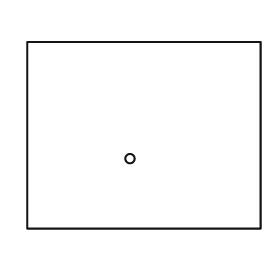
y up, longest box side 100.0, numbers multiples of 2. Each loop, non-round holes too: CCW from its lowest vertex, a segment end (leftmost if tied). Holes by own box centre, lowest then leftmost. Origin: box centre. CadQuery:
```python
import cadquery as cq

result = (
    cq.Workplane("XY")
    .moveTo(-50.0, -40.0)
    .lineTo(50.0, -40.0)
    .lineTo(50.0, 40.0)
    .lineTo(-50.0, 40.0)
    .close()
    .moveTo(-6.0, -10.0)
    .circle(2.0)
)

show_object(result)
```